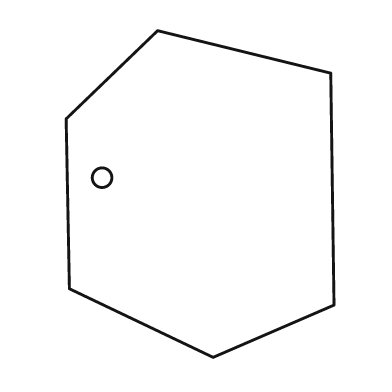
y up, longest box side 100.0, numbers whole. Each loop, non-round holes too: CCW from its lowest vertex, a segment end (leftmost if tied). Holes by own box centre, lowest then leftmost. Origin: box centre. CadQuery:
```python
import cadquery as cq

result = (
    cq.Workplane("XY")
    .moveTo(4.0, -50.0)
    .lineTo(41.0, -34.0)
    .lineTo(40.0, 37.0)
    .lineTo(-13.0, 50.0)
    .lineTo(-41.0, 23.0)
    .lineTo(-40.0, -29.0)
    .close()
    .moveTo(-30.0, 5.0)
    .circle(3.0)
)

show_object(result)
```